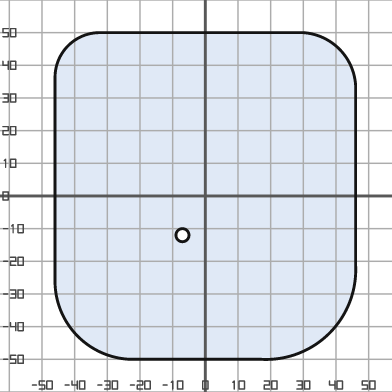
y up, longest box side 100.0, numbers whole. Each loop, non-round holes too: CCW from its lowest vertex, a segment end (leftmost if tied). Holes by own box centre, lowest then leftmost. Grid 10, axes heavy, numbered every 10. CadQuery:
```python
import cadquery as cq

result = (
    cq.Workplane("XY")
    .moveTo(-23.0, -50.0)
    .lineTo(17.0, -50.0)
    .threePointArc((38.0, -42.0), (46.0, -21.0))
    .lineTo(46.0, 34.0)
    .threePointArc((41.0, 45.0), (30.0, 50.0))
    .lineTo(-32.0, 50.0)
    .threePointArc((-42.0, 46.0), (-46.0, 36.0))
    .lineTo(-46.0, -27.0)
    .threePointArc((-39.0, -43.0), (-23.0, -50.0))
    .close()
    .moveTo(-7.0, -12.0)
    .circle(2.0)
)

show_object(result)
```